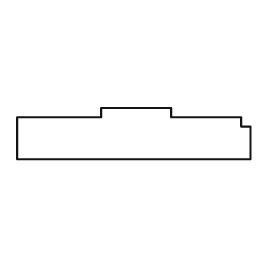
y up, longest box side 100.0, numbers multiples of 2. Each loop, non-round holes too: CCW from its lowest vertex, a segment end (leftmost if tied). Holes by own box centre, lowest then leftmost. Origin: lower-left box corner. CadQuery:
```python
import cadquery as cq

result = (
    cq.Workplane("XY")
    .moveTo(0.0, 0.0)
    .lineTo(100.0, 0.0)
    .lineTo(100.0, 14.0)
    .lineTo(96.0, 14.0)
    .lineTo(96.0, 18.0)
    .lineTo(66.0, 18.0)
    .lineTo(66.0, 22.0)
    .lineTo(36.0, 22.0)
    .lineTo(36.0, 18.0)
    .lineTo(0.0, 18.0)
    .close()
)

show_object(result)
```